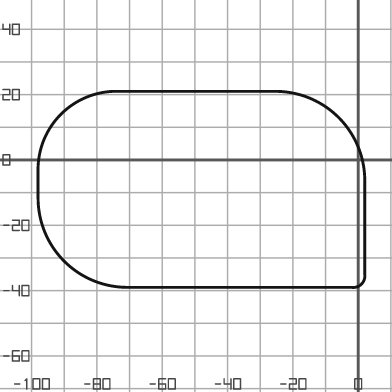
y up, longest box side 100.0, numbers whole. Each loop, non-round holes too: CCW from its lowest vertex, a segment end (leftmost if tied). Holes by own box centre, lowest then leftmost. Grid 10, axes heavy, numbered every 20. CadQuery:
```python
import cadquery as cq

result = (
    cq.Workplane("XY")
    .moveTo(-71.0, -39.0)
    .lineTo(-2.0, -39.0)
    .threePointArc((1.0, -38.0), (2.0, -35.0))
    .lineTo(2.0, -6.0)
    .threePointArc((-6.0, 13.0), (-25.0, 21.0))
    .lineTo(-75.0, 21.0)
    .threePointArc((-91.0, 14.0), (-98.0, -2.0))
    .lineTo(-98.0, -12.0)
    .threePointArc((-90.0, -31.0), (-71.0, -39.0))
    .close()
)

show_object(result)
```